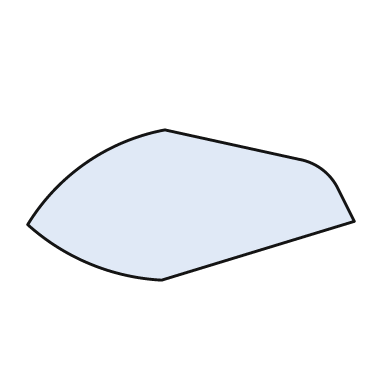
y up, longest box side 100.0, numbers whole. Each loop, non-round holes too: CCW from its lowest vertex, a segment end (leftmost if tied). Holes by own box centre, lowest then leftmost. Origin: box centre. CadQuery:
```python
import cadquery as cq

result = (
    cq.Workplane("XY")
    .moveTo(-9.0, -23.0)
    .lineTo(50.0, -5.0)
    .lineTo(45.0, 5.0)
    .threePointArc((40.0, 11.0), (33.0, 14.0))
    .lineTo(-8.0, 23.0)
    .threePointArc((-32.0, 13.0), (-50.0, -6.0))
    .threePointArc((-31.0, -18.0), (-9.0, -23.0))
    .close()
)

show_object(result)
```